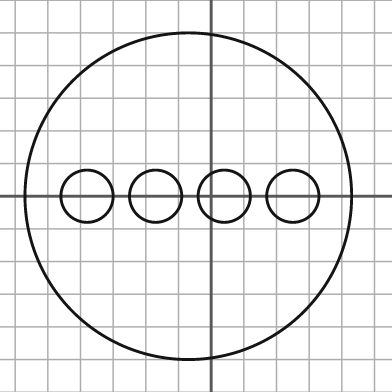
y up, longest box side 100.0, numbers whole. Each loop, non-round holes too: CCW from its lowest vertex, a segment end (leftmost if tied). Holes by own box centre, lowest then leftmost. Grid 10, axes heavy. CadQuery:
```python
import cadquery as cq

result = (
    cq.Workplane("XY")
    .moveTo(-7.0, 0.0)
    .circle(50.0)
    .moveTo(-38.0, 0.0)
    .circle(8.0)
    .moveTo(-17.0, 0.0)
    .circle(8.0)
    .moveTo(4.0, 0.0)
    .circle(8.0)
    .moveTo(25.0, 0.0)
    .circle(8.0)
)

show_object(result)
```